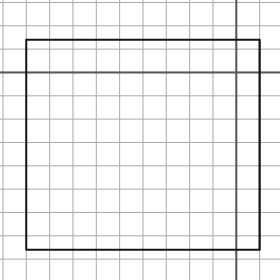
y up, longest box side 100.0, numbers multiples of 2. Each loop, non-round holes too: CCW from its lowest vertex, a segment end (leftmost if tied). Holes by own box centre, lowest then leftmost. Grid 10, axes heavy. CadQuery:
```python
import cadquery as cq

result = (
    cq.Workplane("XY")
    .moveTo(-90.0, -76.0)
    .lineTo(10.0, -76.0)
    .lineTo(10.0, 14.0)
    .lineTo(-90.0, 14.0)
    .close()
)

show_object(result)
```